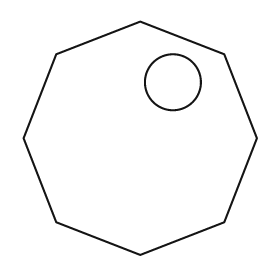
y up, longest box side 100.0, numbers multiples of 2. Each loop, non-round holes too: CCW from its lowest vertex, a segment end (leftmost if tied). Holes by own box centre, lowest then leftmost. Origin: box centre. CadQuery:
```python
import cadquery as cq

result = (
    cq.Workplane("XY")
    .moveTo(0.0, -50.0)
    .lineTo(36.0, -36.0)
    .lineTo(50.0, 0.0)
    .lineTo(36.0, 36.0)
    .lineTo(0.0, 50.0)
    .lineTo(-36.0, 36.0)
    .lineTo(-50.0, 0.0)
    .lineTo(-36.0, -36.0)
    .close()
    .moveTo(14.0, 24.0)
    .circle(12.0)
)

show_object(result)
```